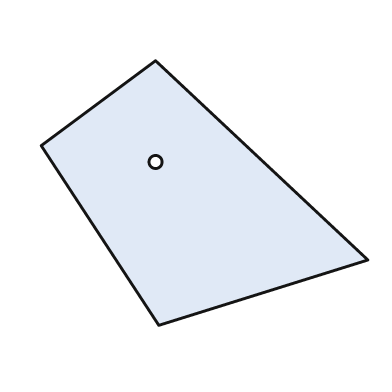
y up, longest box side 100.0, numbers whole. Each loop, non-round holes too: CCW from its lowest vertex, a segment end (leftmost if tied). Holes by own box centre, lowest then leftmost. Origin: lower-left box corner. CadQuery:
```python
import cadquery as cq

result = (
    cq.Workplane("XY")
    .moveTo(36.0, 0.0)
    .lineTo(100.0, 20.0)
    .lineTo(35.0, 81.0)
    .lineTo(0.0, 55.0)
    .close()
    .moveTo(35.0, 50.0)
    .circle(2.0)
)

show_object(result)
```